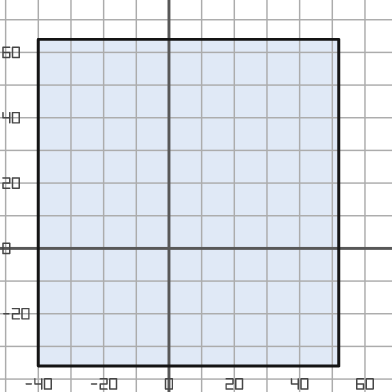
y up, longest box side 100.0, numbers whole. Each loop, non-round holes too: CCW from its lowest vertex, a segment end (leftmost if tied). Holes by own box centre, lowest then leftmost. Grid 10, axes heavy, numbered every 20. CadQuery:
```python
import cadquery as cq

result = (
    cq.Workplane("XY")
    .moveTo(-40.0, -36.0)
    .lineTo(52.0, -36.0)
    .lineTo(52.0, 64.0)
    .lineTo(-40.0, 64.0)
    .close()
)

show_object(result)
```